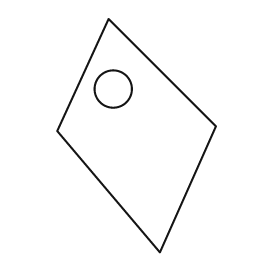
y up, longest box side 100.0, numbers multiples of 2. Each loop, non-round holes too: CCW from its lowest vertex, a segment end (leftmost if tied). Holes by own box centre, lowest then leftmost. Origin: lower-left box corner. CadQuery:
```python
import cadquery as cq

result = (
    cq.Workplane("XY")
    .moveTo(44.0, 0.0)
    .lineTo(68.0, 54.0)
    .lineTo(22.0, 100.0)
    .lineTo(0.0, 52.0)
    .close()
    .moveTo(24.0, 70.0)
    .circle(8.0)
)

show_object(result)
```